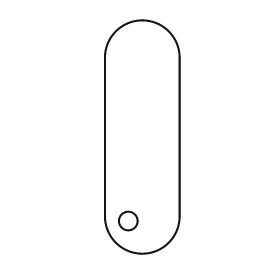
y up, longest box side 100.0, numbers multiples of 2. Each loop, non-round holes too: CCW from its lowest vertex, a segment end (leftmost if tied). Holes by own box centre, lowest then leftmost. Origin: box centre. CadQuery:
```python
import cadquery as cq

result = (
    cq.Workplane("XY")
    .moveTo(-16.0, -34.0)
    .threePointArc((0.0, -50.0), (16.0, -34.0))
    .lineTo(16.0, 34.0)
    .threePointArc((0.0, 50.0), (-16.0, 34.0))
    .close()
    .moveTo(-6.0, -36.0)
    .circle(4.0)
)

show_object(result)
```